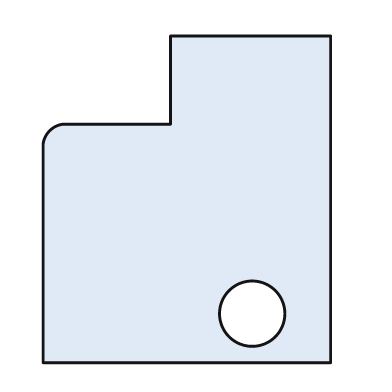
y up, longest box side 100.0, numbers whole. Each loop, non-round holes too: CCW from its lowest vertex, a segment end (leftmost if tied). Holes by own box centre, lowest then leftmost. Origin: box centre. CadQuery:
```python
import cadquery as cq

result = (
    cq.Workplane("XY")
    .moveTo(-44.0, -50.0)
    .lineTo(44.0, -50.0)
    .lineTo(44.0, 50.0)
    .lineTo(-5.0, 50.0)
    .lineTo(-5.0, 23.0)
    .lineTo(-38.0, 23.0)
    .threePointArc((-42.0, 21.0), (-44.0, 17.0))
    .close()
    .moveTo(20.0, -35.0)
    .circle(10.0)
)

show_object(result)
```